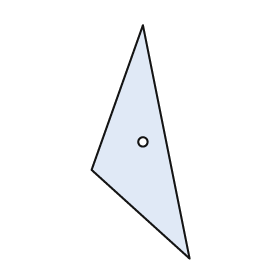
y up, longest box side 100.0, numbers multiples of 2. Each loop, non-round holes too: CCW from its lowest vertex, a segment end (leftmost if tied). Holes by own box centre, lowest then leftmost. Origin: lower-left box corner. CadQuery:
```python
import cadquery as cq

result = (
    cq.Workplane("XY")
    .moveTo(42.0, 0.0)
    .lineTo(22.0, 100.0)
    .lineTo(0.0, 38.0)
    .close()
    .moveTo(22.0, 50.0)
    .circle(2.0)
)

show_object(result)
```